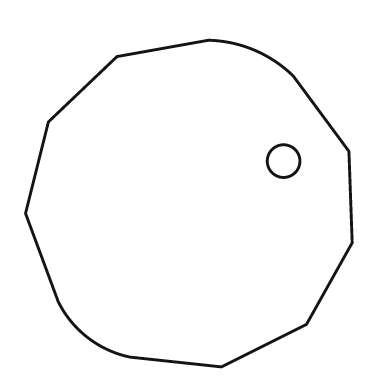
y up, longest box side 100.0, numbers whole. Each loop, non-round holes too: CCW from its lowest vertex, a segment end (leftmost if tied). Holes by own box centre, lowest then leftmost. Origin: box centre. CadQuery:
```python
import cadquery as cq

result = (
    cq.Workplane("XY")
    .moveTo(10.0, -50.0)
    .lineTo(36.0, -37.0)
    .lineTo(50.0, -12.0)
    .lineTo(49.0, 16.0)
    .lineTo(32.0, 39.0)
    .threePointArc((20.0, 47.0), (6.0, 50.0))
    .lineTo(-22.0, 45.0)
    .lineTo(-43.0, 25.0)
    .lineTo(-50.0, -3.0)
    .lineTo(-40.0, -30.0)
    .threePointArc((-31.0, -41.0), (-18.0, -47.0))
    .close()
    .moveTo(29.0, 13.0)
    .circle(5.0)
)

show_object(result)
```